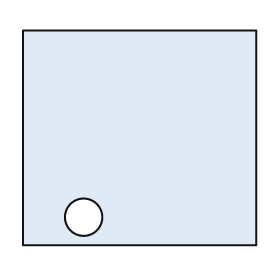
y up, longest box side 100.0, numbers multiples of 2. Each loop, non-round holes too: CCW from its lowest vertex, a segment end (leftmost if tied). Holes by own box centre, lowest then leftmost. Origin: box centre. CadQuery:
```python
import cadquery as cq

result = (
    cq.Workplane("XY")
    .moveTo(-50.0, -46.0)
    .lineTo(50.0, -46.0)
    .lineTo(50.0, 46.0)
    .lineTo(-50.0, 46.0)
    .close()
    .moveTo(-24.0, -34.0)
    .circle(8.0)
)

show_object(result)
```